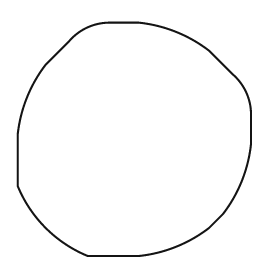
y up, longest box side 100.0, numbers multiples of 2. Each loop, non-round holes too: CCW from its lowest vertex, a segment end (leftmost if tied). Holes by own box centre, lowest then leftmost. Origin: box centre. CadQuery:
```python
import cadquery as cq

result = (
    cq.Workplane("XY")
    .moveTo(-20.0, -50.0)
    .lineTo(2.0, -50.0)
    .threePointArc((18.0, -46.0), (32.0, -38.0))
    .lineTo(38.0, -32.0)
    .threePointArc((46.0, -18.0), (50.0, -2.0))
    .lineTo(50.0, 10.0)
    .threePointArc((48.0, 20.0), (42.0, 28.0))
    .lineTo(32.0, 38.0)
    .threePointArc((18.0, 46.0), (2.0, 50.0))
    .lineTo(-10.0, 50.0)
    .threePointArc((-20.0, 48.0), (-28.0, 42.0))
    .lineTo(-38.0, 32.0)
    .threePointArc((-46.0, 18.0), (-50.0, 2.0))
    .lineTo(-50.0, -20.0)
    .threePointArc((-38.0, -38.0), (-20.0, -50.0))
    .close()
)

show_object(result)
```